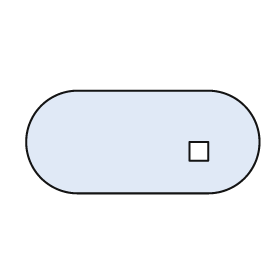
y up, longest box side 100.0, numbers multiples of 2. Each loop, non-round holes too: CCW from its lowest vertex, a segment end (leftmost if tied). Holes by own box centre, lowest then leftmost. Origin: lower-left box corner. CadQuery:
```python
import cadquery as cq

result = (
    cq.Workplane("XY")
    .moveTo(22.0, 0.0)
    .lineTo(78.0, 0.0)
    .threePointArc((100.0, 22.0), (78.0, 44.0))
    .lineTo(22.0, 44.0)
    .threePointArc((0.0, 22.0), (22.0, 0.0))
    .close()
    .moveTo(70.0, 14.0)
    .lineTo(78.0, 14.0)
    .lineTo(78.0, 22.0)
    .lineTo(70.0, 22.0)
    .close()
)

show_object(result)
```